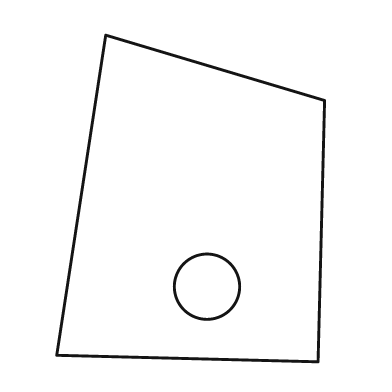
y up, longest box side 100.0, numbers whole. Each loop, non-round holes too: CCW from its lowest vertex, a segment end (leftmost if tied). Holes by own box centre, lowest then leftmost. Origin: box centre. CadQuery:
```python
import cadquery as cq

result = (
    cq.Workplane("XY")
    .moveTo(39.0, -50.0)
    .lineTo(41.0, 30.0)
    .lineTo(-26.0, 50.0)
    .lineTo(-41.0, -48.0)
    .close()
    .moveTo(5.0, -27.0)
    .circle(10.0)
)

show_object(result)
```